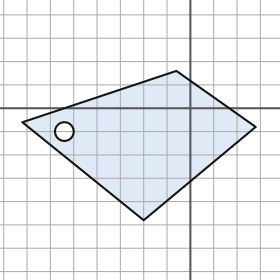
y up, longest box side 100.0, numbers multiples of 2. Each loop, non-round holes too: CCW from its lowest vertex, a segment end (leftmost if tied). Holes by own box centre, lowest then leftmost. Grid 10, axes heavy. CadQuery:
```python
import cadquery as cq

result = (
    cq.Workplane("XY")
    .moveTo(-20.0, -48.0)
    .lineTo(28.0, -8.0)
    .lineTo(-6.0, 16.0)
    .lineTo(-72.0, -6.0)
    .close()
    .moveTo(-54.0, -10.0)
    .circle(4.0)
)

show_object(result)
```